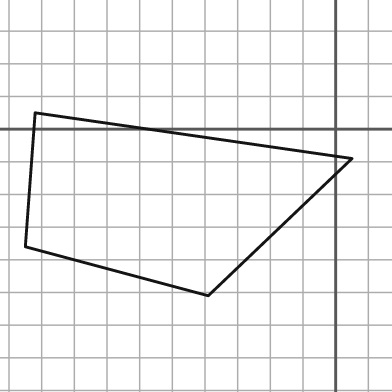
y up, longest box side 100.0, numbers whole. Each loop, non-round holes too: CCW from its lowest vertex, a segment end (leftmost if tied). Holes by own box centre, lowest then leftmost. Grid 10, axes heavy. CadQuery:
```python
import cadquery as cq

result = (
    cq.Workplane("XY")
    .moveTo(-39.0, -51.0)
    .lineTo(5.0, -9.0)
    .lineTo(-92.0, 5.0)
    .lineTo(-95.0, -36.0)
    .close()
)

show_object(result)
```